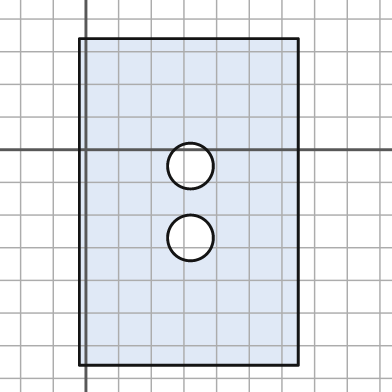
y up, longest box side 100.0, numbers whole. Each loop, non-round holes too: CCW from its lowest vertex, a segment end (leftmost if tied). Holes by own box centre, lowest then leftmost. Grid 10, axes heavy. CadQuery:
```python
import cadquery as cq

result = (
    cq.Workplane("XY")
    .moveTo(-2.0, -66.0)
    .lineTo(65.0, -66.0)
    .lineTo(65.0, 34.0)
    .lineTo(-2.0, 34.0)
    .close()
    .moveTo(32.0, -27.0)
    .circle(7.0)
    .moveTo(32.0, -5.0)
    .circle(7.0)
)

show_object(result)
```